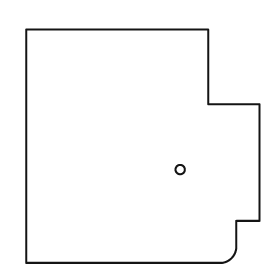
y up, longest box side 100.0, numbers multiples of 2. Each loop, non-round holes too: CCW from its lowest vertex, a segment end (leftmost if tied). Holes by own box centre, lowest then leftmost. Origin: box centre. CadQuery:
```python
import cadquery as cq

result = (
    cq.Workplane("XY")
    .moveTo(-50.0, -50.0)
    .lineTo(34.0, -50.0)
    .threePointArc((38.0, -48.0), (40.0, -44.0))
    .lineTo(40.0, -32.0)
    .lineTo(50.0, -32.0)
    .lineTo(50.0, 18.0)
    .lineTo(28.0, 18.0)
    .lineTo(28.0, 50.0)
    .lineTo(-50.0, 50.0)
    .close()
    .moveTo(16.0, -10.0)
    .circle(2.0)
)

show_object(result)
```